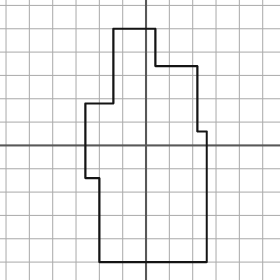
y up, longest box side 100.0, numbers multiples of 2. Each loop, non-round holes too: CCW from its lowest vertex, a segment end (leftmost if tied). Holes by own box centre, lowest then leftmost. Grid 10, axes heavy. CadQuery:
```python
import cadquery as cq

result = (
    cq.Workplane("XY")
    .moveTo(-20.0, -50.0)
    .lineTo(26.0, -50.0)
    .lineTo(26.0, 6.0)
    .lineTo(22.0, 6.0)
    .lineTo(22.0, 34.0)
    .lineTo(4.0, 34.0)
    .lineTo(4.0, 50.0)
    .lineTo(-14.0, 50.0)
    .lineTo(-14.0, 18.0)
    .lineTo(-26.0, 18.0)
    .lineTo(-26.0, -14.0)
    .lineTo(-20.0, -14.0)
    .close()
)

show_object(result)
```